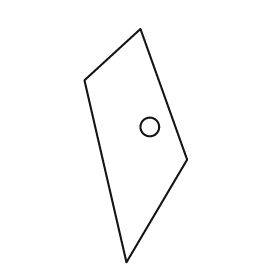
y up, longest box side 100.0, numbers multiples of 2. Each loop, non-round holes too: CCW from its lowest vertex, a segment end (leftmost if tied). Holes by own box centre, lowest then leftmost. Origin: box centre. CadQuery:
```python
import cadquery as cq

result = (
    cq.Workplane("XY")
    .moveTo(-4.0, -50.0)
    .lineTo(22.0, -6.0)
    .lineTo(2.0, 50.0)
    .lineTo(-22.0, 28.0)
    .close()
    .moveTo(6.0, 8.0)
    .circle(4.0)
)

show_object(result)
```